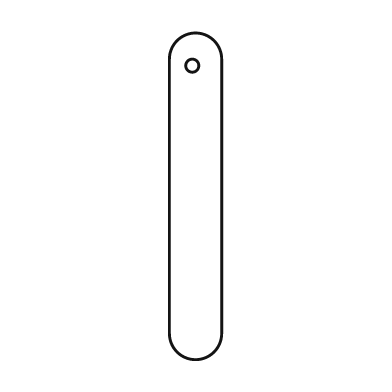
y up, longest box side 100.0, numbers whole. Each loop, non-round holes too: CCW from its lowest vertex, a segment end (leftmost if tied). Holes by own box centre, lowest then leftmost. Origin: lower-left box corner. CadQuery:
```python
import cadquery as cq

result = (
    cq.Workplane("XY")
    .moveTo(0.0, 8.0)
    .threePointArc((8.0, 0.0), (16.0, 8.0))
    .lineTo(16.0, 92.0)
    .threePointArc((8.0, 100.0), (0.0, 92.0))
    .close()
    .moveTo(7.0, 90.0)
    .circle(2.0)
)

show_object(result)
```